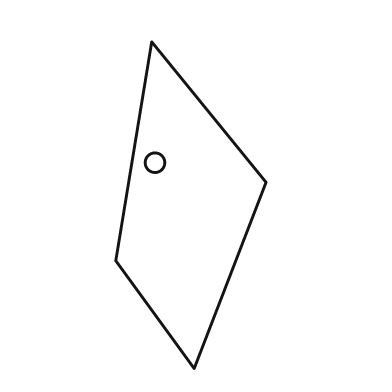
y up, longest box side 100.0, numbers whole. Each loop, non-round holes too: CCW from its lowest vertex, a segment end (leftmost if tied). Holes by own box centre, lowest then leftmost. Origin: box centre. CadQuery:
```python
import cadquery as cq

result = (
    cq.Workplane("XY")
    .moveTo(1.0, -50.0)
    .lineTo(23.0, 7.0)
    .lineTo(-12.0, 50.0)
    .lineTo(-23.0, -17.0)
    .close()
    .moveTo(-11.0, 13.0)
    .circle(3.0)
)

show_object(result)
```